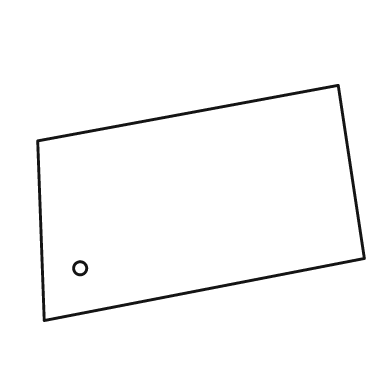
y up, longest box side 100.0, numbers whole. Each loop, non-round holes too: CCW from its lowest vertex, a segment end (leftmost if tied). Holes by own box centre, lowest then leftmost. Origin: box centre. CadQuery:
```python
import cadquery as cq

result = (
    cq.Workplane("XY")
    .moveTo(-48.0, -36.0)
    .lineTo(50.0, -17.0)
    .lineTo(42.0, 36.0)
    .lineTo(-50.0, 19.0)
    .close()
    .moveTo(-37.0, -20.0)
    .circle(2.0)
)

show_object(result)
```